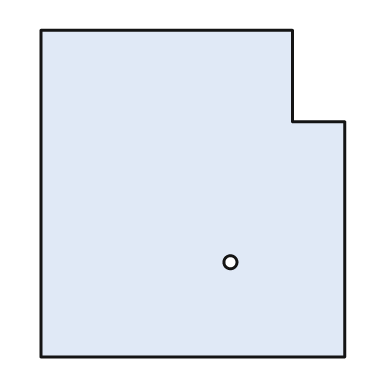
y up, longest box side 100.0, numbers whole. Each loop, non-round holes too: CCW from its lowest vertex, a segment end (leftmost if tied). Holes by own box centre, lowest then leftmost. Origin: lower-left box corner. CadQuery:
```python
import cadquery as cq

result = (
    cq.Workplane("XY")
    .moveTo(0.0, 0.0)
    .lineTo(93.0, 0.0)
    .lineTo(93.0, 72.0)
    .lineTo(77.0, 72.0)
    .lineTo(77.0, 100.0)
    .lineTo(0.0, 100.0)
    .close()
    .moveTo(58.0, 29.0)
    .circle(2.0)
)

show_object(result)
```